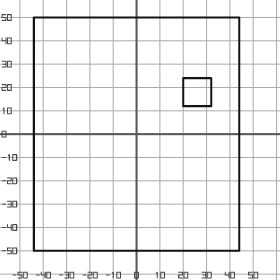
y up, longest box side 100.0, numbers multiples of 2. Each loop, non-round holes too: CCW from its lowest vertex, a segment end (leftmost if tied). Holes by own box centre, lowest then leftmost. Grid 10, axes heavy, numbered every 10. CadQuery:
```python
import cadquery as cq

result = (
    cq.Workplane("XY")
    .moveTo(-44.0, -50.0)
    .lineTo(44.0, -50.0)
    .lineTo(44.0, 50.0)
    .lineTo(-44.0, 50.0)
    .close()
    .moveTo(20.0, 12.0)
    .lineTo(32.0, 12.0)
    .lineTo(32.0, 24.0)
    .lineTo(20.0, 24.0)
    .close()
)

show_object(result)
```